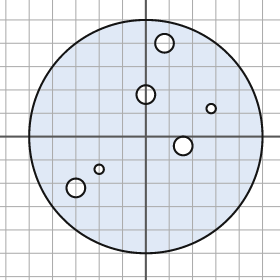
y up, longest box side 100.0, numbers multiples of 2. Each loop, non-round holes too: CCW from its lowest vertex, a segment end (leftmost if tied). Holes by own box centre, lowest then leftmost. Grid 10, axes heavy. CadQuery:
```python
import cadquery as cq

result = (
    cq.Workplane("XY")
    .moveTo(0.0, 0.0)
    .circle(50.0)
    .moveTo(-30.0, -22.0)
    .circle(4.0)
    .moveTo(-20.0, -14.0)
    .circle(2.0)
    .moveTo(16.0, -4.0)
    .circle(4.0)
    .moveTo(28.0, 12.0)
    .circle(2.0)
    .moveTo(0.0, 18.0)
    .circle(4.0)
    .moveTo(8.0, 40.0)
    .circle(4.0)
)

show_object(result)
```